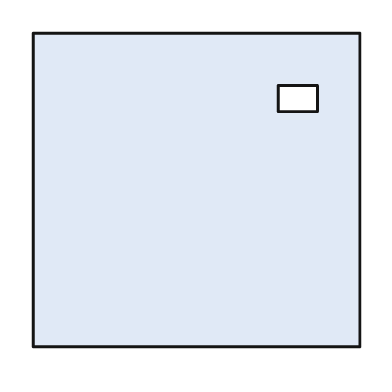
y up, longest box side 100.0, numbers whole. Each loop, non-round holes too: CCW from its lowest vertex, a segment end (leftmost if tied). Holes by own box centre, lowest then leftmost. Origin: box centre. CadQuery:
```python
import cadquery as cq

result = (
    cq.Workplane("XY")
    .moveTo(-50.0, -48.0)
    .lineTo(50.0, -48.0)
    .lineTo(50.0, 48.0)
    .lineTo(-50.0, 48.0)
    .close()
    .moveTo(25.0, 24.0)
    .lineTo(37.0, 24.0)
    .lineTo(37.0, 32.0)
    .lineTo(25.0, 32.0)
    .close()
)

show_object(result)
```